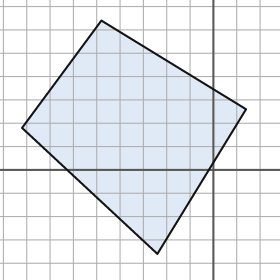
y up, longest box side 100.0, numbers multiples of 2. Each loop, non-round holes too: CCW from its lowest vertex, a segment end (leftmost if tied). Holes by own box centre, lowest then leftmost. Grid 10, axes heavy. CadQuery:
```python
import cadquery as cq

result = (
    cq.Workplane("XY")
    .moveTo(-24.0, -36.0)
    .lineTo(14.0, 26.0)
    .lineTo(-48.0, 64.0)
    .lineTo(-82.0, 18.0)
    .close()
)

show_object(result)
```